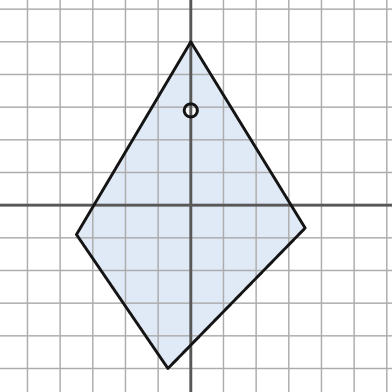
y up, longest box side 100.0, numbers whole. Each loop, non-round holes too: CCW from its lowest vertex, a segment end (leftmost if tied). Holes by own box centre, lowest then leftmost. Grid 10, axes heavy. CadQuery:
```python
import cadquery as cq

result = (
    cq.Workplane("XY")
    .moveTo(-7.0, -50.0)
    .lineTo(35.0, -7.0)
    .lineTo(0.0, 50.0)
    .lineTo(-35.0, -9.0)
    .close()
    .moveTo(0.0, 29.0)
    .circle(2.0)
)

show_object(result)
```